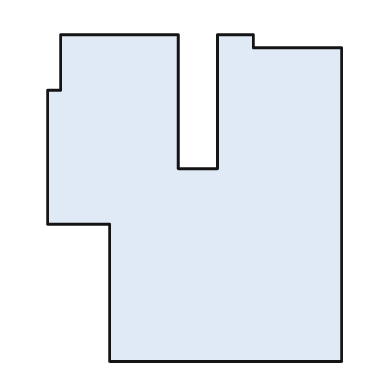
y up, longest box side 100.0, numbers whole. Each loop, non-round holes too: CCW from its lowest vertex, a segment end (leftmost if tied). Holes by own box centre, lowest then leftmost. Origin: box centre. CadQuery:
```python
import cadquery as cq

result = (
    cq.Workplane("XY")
    .moveTo(-26.0, -50.0)
    .lineTo(45.0, -50.0)
    .lineTo(45.0, 46.0)
    .lineTo(18.0, 46.0)
    .lineTo(18.0, 50.0)
    .lineTo(7.0, 50.0)
    .lineTo(7.0, 9.0)
    .lineTo(-5.0, 9.0)
    .lineTo(-5.0, 50.0)
    .lineTo(-41.0, 50.0)
    .lineTo(-41.0, 33.0)
    .lineTo(-45.0, 33.0)
    .lineTo(-45.0, -8.0)
    .lineTo(-26.0, -8.0)
    .close()
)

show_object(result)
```